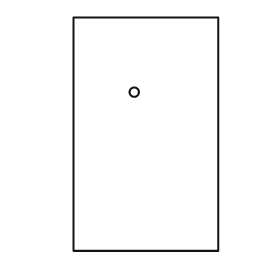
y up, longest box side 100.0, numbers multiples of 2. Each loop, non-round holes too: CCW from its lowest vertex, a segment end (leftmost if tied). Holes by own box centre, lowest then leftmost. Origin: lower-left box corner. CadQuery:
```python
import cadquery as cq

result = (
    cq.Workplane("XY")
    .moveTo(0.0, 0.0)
    .lineTo(62.0, 0.0)
    .lineTo(62.0, 100.0)
    .lineTo(0.0, 100.0)
    .close()
    .moveTo(26.0, 68.0)
    .circle(2.0)
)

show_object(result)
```